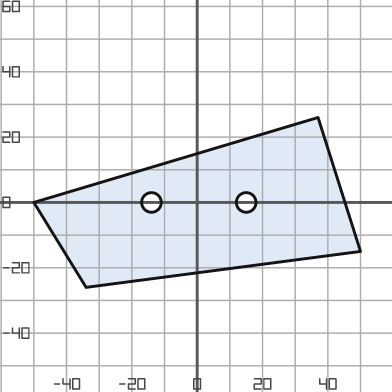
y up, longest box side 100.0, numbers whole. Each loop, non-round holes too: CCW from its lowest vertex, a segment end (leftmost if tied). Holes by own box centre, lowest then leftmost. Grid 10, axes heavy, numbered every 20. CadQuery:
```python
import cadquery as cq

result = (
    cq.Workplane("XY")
    .moveTo(-34.0, -26.0)
    .lineTo(50.0, -15.0)
    .lineTo(37.0, 26.0)
    .lineTo(-50.0, 0.0)
    .close()
    .moveTo(-14.0, 0.0)
    .circle(3.0)
    .moveTo(15.0, 0.0)
    .circle(3.0)
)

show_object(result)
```